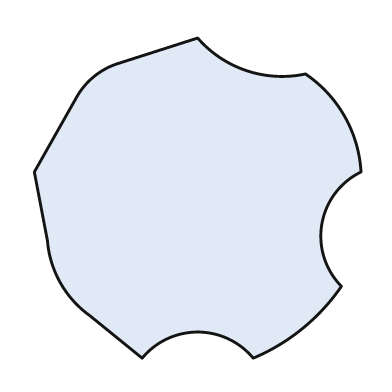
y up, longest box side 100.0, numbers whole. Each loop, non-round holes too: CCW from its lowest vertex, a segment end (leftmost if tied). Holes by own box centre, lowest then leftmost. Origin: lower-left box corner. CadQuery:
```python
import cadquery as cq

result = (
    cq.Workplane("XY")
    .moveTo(33.0, 0.0)
    .threePointArc((50.0, 8.0), (67.0, 0.0))
    .threePointArc((82.0, 9.0), (94.0, 22.0))
    .threePointArc((88.0, 41.0), (100.0, 57.0))
    .threePointArc((95.0, 74.0), (83.0, 87.0))
    .threePointArc((65.0, 88.0), (50.0, 98.0))
    .lineTo(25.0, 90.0)
    .threePointArc((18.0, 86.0), (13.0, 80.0))
    .lineTo(0.0, 57.0)
    .lineTo(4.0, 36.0)
    .threePointArc((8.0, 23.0), (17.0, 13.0))
    .close()
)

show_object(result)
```